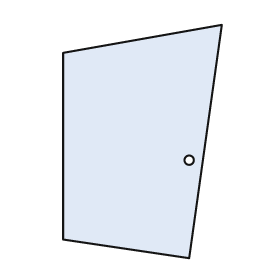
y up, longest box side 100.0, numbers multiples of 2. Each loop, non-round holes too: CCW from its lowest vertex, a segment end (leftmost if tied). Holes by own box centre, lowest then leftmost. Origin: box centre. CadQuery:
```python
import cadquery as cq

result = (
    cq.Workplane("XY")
    .moveTo(20.0, -50.0)
    .lineTo(34.0, 50.0)
    .lineTo(-34.0, 38.0)
    .lineTo(-34.0, -42.0)
    .close()
    .moveTo(20.0, -8.0)
    .circle(2.0)
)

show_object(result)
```